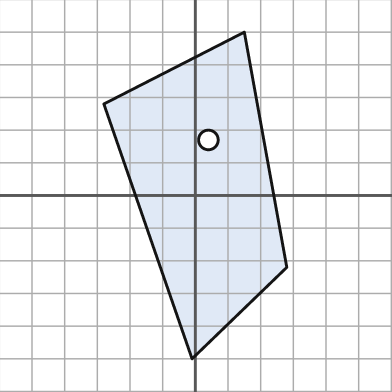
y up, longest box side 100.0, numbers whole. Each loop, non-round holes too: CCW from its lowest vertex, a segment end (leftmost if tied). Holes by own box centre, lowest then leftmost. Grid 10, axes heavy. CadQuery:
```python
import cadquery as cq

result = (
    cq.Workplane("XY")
    .moveTo(-1.0, -50.0)
    .lineTo(28.0, -22.0)
    .lineTo(15.0, 50.0)
    .lineTo(-28.0, 28.0)
    .close()
    .moveTo(4.0, 17.0)
    .circle(3.0)
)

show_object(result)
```